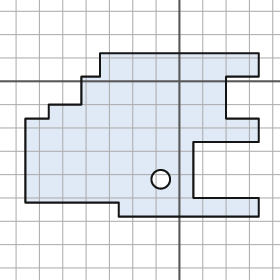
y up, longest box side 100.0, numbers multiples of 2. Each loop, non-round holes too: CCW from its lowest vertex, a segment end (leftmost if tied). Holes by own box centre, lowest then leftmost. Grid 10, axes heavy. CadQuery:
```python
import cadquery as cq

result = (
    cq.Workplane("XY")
    .moveTo(-26.0, -58.0)
    .lineTo(34.0, -58.0)
    .lineTo(34.0, -50.0)
    .lineTo(6.0, -50.0)
    .lineTo(6.0, -26.0)
    .lineTo(34.0, -26.0)
    .lineTo(34.0, -16.0)
    .lineTo(20.0, -16.0)
    .lineTo(20.0, 2.0)
    .lineTo(34.0, 2.0)
    .lineTo(34.0, 12.0)
    .lineTo(-34.0, 12.0)
    .lineTo(-34.0, 2.0)
    .lineTo(-42.0, 2.0)
    .lineTo(-42.0, -10.0)
    .lineTo(-56.0, -10.0)
    .lineTo(-56.0, -16.0)
    .lineTo(-66.0, -16.0)
    .lineTo(-66.0, -52.0)
    .lineTo(-26.0, -52.0)
    .close()
    .moveTo(-8.0, -42.0)
    .circle(4.0)
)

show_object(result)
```